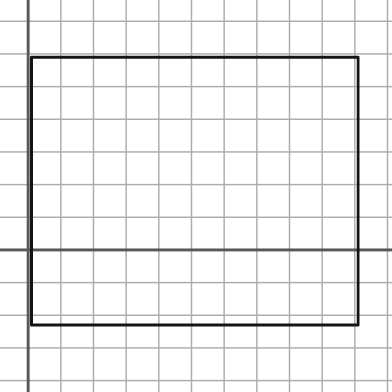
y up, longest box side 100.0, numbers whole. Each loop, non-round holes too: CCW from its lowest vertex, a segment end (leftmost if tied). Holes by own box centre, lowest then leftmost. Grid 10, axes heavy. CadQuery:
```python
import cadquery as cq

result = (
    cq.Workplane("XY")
    .moveTo(1.0, -23.0)
    .lineTo(101.0, -23.0)
    .lineTo(101.0, 59.0)
    .lineTo(1.0, 59.0)
    .close()
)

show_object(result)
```